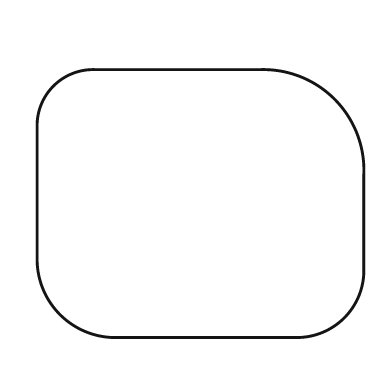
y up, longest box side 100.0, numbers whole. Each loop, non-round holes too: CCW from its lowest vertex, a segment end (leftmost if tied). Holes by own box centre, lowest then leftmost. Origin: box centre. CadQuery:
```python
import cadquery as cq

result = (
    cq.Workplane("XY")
    .moveTo(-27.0, -41.0)
    .lineTo(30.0, -41.0)
    .threePointArc((44.0, -35.0), (50.0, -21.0))
    .lineTo(50.0, 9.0)
    .threePointArc((41.0, 32.0), (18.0, 41.0))
    .lineTo(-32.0, 41.0)
    .threePointArc((-45.0, 36.0), (-50.0, 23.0))
    .lineTo(-50.0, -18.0)
    .threePointArc((-43.0, -34.0), (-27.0, -41.0))
    .close()
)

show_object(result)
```